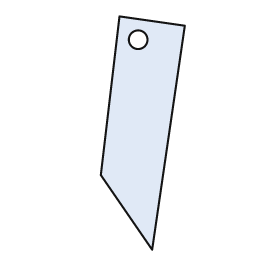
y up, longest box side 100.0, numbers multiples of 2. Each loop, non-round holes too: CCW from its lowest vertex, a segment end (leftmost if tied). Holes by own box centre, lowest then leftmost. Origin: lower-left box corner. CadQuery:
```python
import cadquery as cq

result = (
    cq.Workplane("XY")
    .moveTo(22.0, 0.0)
    .lineTo(36.0, 96.0)
    .lineTo(8.0, 100.0)
    .lineTo(0.0, 32.0)
    .close()
    .moveTo(16.0, 90.0)
    .circle(4.0)
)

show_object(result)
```